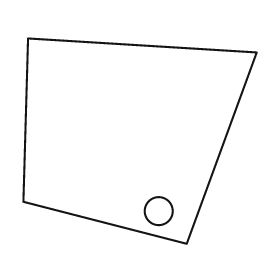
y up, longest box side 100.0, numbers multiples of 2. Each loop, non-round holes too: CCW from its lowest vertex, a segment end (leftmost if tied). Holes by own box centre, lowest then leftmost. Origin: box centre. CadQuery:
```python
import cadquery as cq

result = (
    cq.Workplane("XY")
    .moveTo(20.0, -44.0)
    .lineTo(50.0, 38.0)
    .lineTo(-48.0, 44.0)
    .lineTo(-50.0, -26.0)
    .close()
    .moveTo(8.0, -30.0)
    .circle(6.0)
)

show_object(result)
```